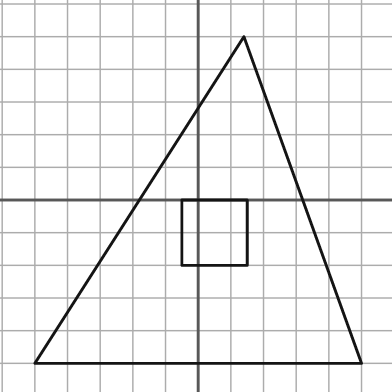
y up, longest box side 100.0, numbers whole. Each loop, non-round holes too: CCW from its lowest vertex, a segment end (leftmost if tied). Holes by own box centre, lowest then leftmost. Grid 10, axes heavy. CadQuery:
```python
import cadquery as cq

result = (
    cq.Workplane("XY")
    .moveTo(-50.0, -50.0)
    .lineTo(50.0, -50.0)
    .lineTo(14.0, 50.0)
    .close()
    .moveTo(-5.0, -20.0)
    .lineTo(15.0, -20.0)
    .lineTo(15.0, 0.0)
    .lineTo(-5.0, 0.0)
    .close()
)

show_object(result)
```